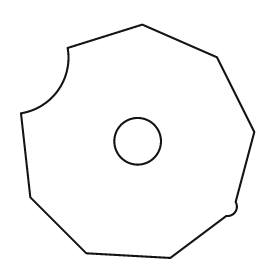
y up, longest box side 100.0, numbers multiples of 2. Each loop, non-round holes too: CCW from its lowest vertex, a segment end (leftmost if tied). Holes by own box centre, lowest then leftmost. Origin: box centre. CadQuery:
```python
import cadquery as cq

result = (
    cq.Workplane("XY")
    .moveTo(14.0, -50.0)
    .lineTo(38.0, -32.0)
    .threePointArc((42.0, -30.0), (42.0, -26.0))
    .lineTo(50.0, 4.0)
    .lineTo(34.0, 36.0)
    .lineTo(2.0, 50.0)
    .lineTo(-30.0, 40.0)
    .threePointArc((-34.0, 22.0), (-50.0, 12.0))
    .lineTo(-46.0, -24.0)
    .lineTo(-22.0, -48.0)
    .close()
    .moveTo(0.0, 0.0)
    .circle(10.0)
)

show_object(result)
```